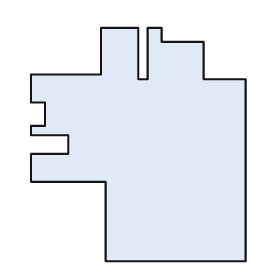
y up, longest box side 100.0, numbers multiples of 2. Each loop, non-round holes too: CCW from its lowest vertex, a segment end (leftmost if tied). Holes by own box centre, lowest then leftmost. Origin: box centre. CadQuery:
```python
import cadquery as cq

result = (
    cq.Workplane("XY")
    .moveTo(-14.0, -50.0)
    .lineTo(46.0, -50.0)
    .lineTo(46.0, 28.0)
    .lineTo(28.0, 28.0)
    .lineTo(28.0, 44.0)
    .lineTo(10.0, 44.0)
    .lineTo(10.0, 50.0)
    .lineTo(4.0, 50.0)
    .lineTo(4.0, 28.0)
    .lineTo(0.0, 28.0)
    .lineTo(0.0, 50.0)
    .lineTo(-16.0, 50.0)
    .lineTo(-16.0, 30.0)
    .lineTo(-46.0, 30.0)
    .lineTo(-46.0, 18.0)
    .lineTo(-40.0, 18.0)
    .lineTo(-40.0, 8.0)
    .lineTo(-46.0, 8.0)
    .lineTo(-46.0, 4.0)
    .lineTo(-30.0, 4.0)
    .lineTo(-30.0, -4.0)
    .lineTo(-46.0, -4.0)
    .lineTo(-46.0, -16.0)
    .lineTo(-14.0, -16.0)
    .close()
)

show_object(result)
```